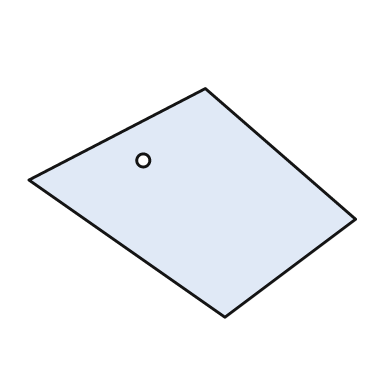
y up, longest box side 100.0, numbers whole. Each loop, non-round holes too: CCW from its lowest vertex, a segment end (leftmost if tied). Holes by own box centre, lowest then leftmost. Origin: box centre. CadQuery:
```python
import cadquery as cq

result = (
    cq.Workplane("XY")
    .moveTo(10.0, -35.0)
    .lineTo(50.0, -5.0)
    .lineTo(4.0, 35.0)
    .lineTo(-50.0, 7.0)
    .close()
    .moveTo(-15.0, 13.0)
    .circle(2.0)
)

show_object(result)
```